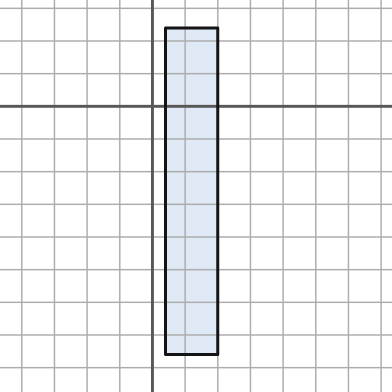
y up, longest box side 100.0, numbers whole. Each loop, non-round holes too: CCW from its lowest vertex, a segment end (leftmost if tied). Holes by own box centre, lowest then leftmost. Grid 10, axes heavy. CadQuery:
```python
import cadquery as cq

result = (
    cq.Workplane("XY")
    .moveTo(4.0, -76.0)
    .lineTo(20.0, -76.0)
    .lineTo(20.0, 24.0)
    .lineTo(4.0, 24.0)
    .close()
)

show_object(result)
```